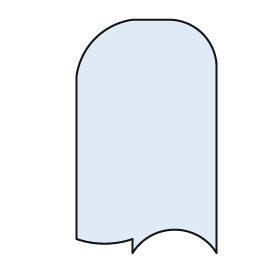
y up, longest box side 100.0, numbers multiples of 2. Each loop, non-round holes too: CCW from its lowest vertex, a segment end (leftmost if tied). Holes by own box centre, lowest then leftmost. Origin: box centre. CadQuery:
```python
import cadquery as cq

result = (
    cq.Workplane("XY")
    .moveTo(-6.0, -50.0)
    .threePointArc((12.0, -40.0), (30.0, -50.0))
    .lineTo(30.0, 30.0)
    .threePointArc((24.0, 44.0), (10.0, 50.0))
    .lineTo(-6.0, 50.0)
    .threePointArc((-22.0, 42.0), (-30.0, 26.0))
    .lineTo(-30.0, -44.0)
    .threePointArc((-18.0, -46.0), (-6.0, -44.0))
    .close()
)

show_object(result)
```